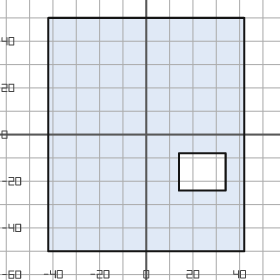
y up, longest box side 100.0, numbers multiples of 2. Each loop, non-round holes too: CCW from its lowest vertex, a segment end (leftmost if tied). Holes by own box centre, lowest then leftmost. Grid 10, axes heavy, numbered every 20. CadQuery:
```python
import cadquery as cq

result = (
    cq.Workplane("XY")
    .moveTo(-42.0, -50.0)
    .lineTo(42.0, -50.0)
    .lineTo(42.0, 50.0)
    .lineTo(-42.0, 50.0)
    .close()
    .moveTo(14.0, -24.0)
    .lineTo(34.0, -24.0)
    .lineTo(34.0, -8.0)
    .lineTo(14.0, -8.0)
    .close()
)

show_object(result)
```